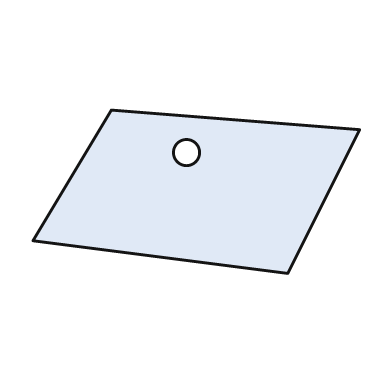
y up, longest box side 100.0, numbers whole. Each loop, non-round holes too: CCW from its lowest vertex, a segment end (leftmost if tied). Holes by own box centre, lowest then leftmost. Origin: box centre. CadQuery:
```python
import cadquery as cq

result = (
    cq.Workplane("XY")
    .moveTo(28.0, -25.0)
    .lineTo(50.0, 19.0)
    .lineTo(-26.0, 25.0)
    .lineTo(-50.0, -15.0)
    .close()
    .moveTo(-3.0, 12.0)
    .circle(4.0)
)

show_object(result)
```